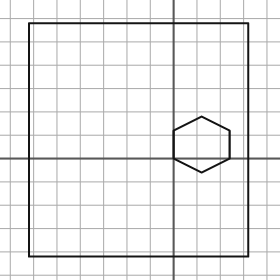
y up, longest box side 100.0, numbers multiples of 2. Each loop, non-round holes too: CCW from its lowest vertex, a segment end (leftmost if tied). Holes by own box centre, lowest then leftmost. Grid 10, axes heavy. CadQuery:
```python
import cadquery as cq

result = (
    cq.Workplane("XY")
    .moveTo(-62.0, -42.0)
    .lineTo(32.0, -42.0)
    .lineTo(32.0, 58.0)
    .lineTo(-62.0, 58.0)
    .close()
    .moveTo(12.0, -6.0)
    .lineTo(24.0, 0.0)
    .lineTo(24.0, 12.0)
    .lineTo(12.0, 18.0)
    .lineTo(0.0, 12.0)
    .lineTo(0.0, 0.0)
    .close()
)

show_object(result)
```